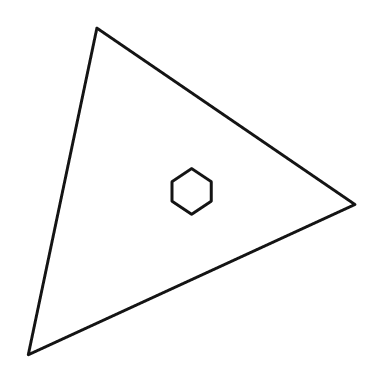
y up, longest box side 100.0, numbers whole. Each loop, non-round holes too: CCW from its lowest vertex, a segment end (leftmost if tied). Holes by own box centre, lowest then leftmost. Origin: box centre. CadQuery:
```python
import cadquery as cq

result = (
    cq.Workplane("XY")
    .moveTo(-50.0, -50.0)
    .lineTo(50.0, -4.0)
    .lineTo(-29.0, 50.0)
    .close()
    .moveTo(0.0, -7.0)
    .lineTo(6.0, -3.0)
    .lineTo(6.0, 3.0)
    .lineTo(0.0, 7.0)
    .lineTo(-6.0, 3.0)
    .lineTo(-6.0, -3.0)
    .close()
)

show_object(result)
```